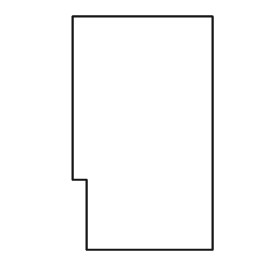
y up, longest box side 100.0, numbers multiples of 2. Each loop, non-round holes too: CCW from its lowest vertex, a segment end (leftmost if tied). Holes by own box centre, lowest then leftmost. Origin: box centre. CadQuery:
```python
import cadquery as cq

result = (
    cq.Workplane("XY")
    .moveTo(-24.0, -50.0)
    .lineTo(30.0, -50.0)
    .lineTo(30.0, 50.0)
    .lineTo(-30.0, 50.0)
    .lineTo(-30.0, -20.0)
    .lineTo(-24.0, -20.0)
    .close()
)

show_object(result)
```